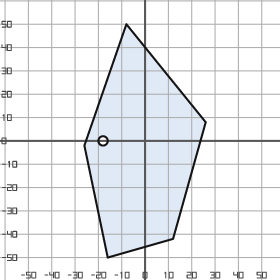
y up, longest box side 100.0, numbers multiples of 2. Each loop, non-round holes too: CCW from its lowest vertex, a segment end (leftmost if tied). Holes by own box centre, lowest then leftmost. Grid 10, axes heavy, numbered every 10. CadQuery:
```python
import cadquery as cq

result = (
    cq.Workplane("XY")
    .moveTo(-16.0, -50.0)
    .lineTo(12.0, -42.0)
    .lineTo(26.0, 8.0)
    .lineTo(-8.0, 50.0)
    .lineTo(-26.0, -2.0)
    .close()
    .moveTo(-18.0, 0.0)
    .circle(2.0)
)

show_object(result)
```